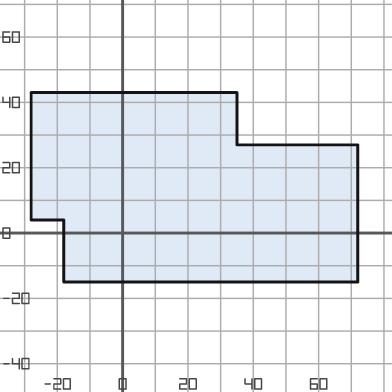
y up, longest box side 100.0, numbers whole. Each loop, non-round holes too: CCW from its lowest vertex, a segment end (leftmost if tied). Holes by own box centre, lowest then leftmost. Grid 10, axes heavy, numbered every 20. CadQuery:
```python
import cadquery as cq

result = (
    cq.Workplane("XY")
    .moveTo(-18.0, -15.0)
    .lineTo(72.0, -15.0)
    .lineTo(72.0, 27.0)
    .lineTo(35.0, 27.0)
    .lineTo(35.0, 43.0)
    .lineTo(-28.0, 43.0)
    .lineTo(-28.0, 4.0)
    .lineTo(-18.0, 4.0)
    .close()
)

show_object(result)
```